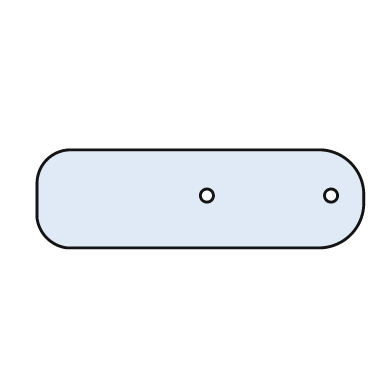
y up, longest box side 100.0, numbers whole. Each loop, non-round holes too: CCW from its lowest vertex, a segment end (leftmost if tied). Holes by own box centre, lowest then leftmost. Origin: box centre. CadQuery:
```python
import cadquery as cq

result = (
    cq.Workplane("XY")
    .moveTo(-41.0, -15.0)
    .lineTo(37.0, -15.0)
    .threePointArc((46.0, -11.0), (50.0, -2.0))
    .lineTo(50.0, 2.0)
    .threePointArc((46.0, 11.0), (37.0, 15.0))
    .lineTo(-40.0, 15.0)
    .threePointArc((-47.0, 12.0), (-50.0, 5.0))
    .lineTo(-50.0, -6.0)
    .threePointArc((-47.0, -12.0), (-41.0, -15.0))
    .close()
    .moveTo(2.0, 1.0)
    .circle(2.0)
    .moveTo(40.0, 1.0)
    .circle(2.0)
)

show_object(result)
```